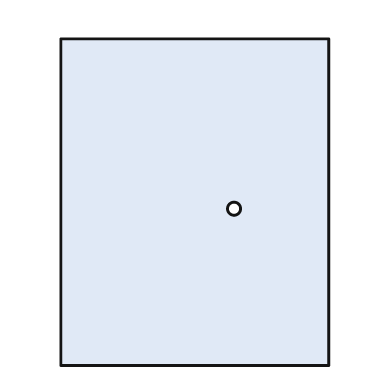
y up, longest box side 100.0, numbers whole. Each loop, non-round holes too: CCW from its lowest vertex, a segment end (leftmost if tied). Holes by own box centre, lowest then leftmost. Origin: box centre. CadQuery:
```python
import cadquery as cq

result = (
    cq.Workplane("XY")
    .moveTo(-41.0, -50.0)
    .lineTo(41.0, -50.0)
    .lineTo(41.0, 50.0)
    .lineTo(-41.0, 50.0)
    .close()
    .moveTo(12.0, -2.0)
    .circle(2.0)
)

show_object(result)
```